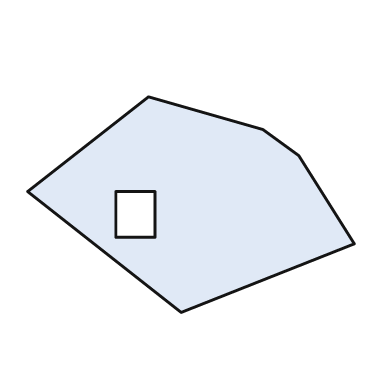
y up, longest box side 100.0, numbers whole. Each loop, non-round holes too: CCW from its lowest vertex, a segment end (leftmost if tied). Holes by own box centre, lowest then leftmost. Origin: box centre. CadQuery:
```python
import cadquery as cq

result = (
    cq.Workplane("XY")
    .moveTo(-3.0, -33.0)
    .lineTo(50.0, -12.0)
    .lineTo(33.0, 15.0)
    .lineTo(22.0, 23.0)
    .lineTo(-13.0, 33.0)
    .lineTo(-50.0, 4.0)
    .close()
    .moveTo(-23.0, -10.0)
    .lineTo(-11.0, -10.0)
    .lineTo(-11.0, 4.0)
    .lineTo(-23.0, 4.0)
    .close()
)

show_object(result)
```